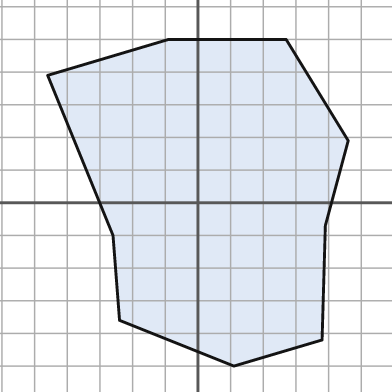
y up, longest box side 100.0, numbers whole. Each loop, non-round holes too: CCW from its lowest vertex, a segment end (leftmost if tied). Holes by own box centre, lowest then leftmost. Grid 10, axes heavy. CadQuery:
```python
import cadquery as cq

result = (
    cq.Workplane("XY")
    .moveTo(11.0, -50.0)
    .lineTo(38.0, -42.0)
    .lineTo(39.0, -7.0)
    .lineTo(46.0, 19.0)
    .lineTo(27.0, 50.0)
    .lineTo(-9.0, 50.0)
    .lineTo(-46.0, 39.0)
    .lineTo(-26.0, -10.0)
    .lineTo(-24.0, -36.0)
    .close()
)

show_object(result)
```